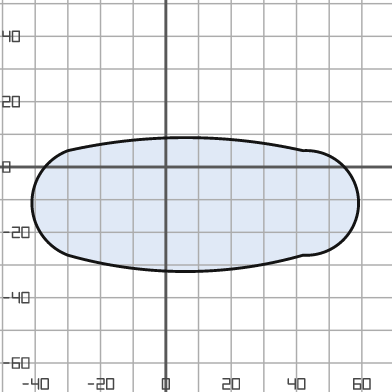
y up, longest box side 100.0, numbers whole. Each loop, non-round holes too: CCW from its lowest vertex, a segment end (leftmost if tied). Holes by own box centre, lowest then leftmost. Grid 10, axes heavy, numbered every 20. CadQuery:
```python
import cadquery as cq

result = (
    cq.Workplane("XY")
    .moveTo(-30.0, -27.0)
    .threePointArc((6.0, -32.0), (42.0, -27.0))
    .threePointArc((59.0, -11.0), (42.0, 5.0))
    .threePointArc((6.0, 9.0), (-30.0, 5.0))
    .threePointArc((-41.0, -11.0), (-30.0, -27.0))
    .close()
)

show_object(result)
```